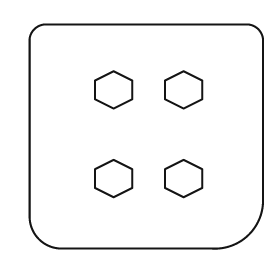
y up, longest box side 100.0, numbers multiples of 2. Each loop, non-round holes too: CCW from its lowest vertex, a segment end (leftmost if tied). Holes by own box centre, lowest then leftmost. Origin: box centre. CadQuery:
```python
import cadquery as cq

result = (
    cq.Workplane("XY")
    .moveTo(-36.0, -48.0)
    .lineTo(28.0, -48.0)
    .threePointArc((44.0, -42.0), (50.0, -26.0))
    .lineTo(50.0, 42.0)
    .threePointArc((48.0, 46.0), (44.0, 48.0))
    .lineTo(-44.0, 48.0)
    .threePointArc((-48.0, 46.0), (-50.0, 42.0))
    .lineTo(-50.0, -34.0)
    .threePointArc((-46.0, -44.0), (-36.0, -48.0))
    .close()
    .moveTo(-14.0, -26.0)
    .lineTo(-6.0, -22.0)
    .lineTo(-6.0, -14.0)
    .lineTo(-14.0, -10.0)
    .lineTo(-22.0, -14.0)
    .lineTo(-22.0, -22.0)
    .close()
    .moveTo(16.0, -26.0)
    .lineTo(24.0, -22.0)
    .lineTo(24.0, -14.0)
    .lineTo(16.0, -10.0)
    .lineTo(8.0, -14.0)
    .lineTo(8.0, -22.0)
    .close()
    .moveTo(-14.0, 12.0)
    .lineTo(-6.0, 16.0)
    .lineTo(-6.0, 24.0)
    .lineTo(-14.0, 28.0)
    .lineTo(-22.0, 24.0)
    .lineTo(-22.0, 16.0)
    .close()
    .moveTo(16.0, 12.0)
    .lineTo(24.0, 16.0)
    .lineTo(24.0, 24.0)
    .lineTo(16.0, 28.0)
    .lineTo(8.0, 24.0)
    .lineTo(8.0, 16.0)
    .close()
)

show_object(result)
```